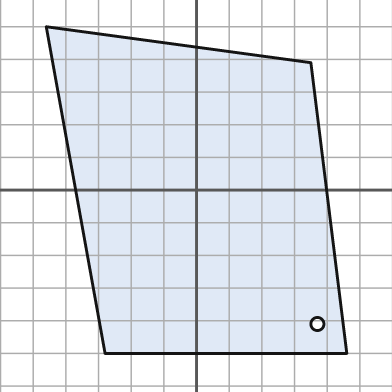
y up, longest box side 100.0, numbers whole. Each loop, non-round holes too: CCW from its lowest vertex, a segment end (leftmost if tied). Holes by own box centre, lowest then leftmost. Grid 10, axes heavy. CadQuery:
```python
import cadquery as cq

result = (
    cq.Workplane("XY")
    .moveTo(-28.0, -50.0)
    .lineTo(46.0, -50.0)
    .lineTo(35.0, 39.0)
    .lineTo(-46.0, 50.0)
    .close()
    .moveTo(37.0, -41.0)
    .circle(2.0)
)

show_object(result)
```